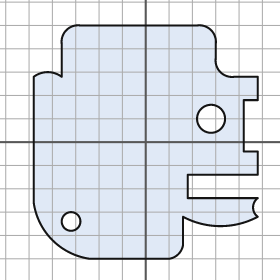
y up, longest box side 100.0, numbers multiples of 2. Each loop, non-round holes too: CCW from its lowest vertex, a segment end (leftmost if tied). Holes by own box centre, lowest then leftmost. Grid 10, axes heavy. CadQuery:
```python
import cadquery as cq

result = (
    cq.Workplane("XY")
    .moveTo(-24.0, -50.0)
    .lineTo(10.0, -50.0)
    .threePointArc((14.0, -48.0), (16.0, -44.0))
    .lineTo(16.0, -32.0)
    .threePointArc((32.0, -36.0), (48.0, -32.0))
    .threePointArc((46.0, -28.0), (48.0, -24.0))
    .lineTo(18.0, -24.0)
    .lineTo(18.0, -14.0)
    .lineTo(48.0, -14.0)
    .lineTo(48.0, -4.0)
    .lineTo(42.0, -4.0)
    .lineTo(42.0, 18.0)
    .lineTo(48.0, 18.0)
    .lineTo(48.0, 28.0)
    .lineTo(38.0, 28.0)
    .threePointArc((32.0, 30.0), (30.0, 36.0))
    .lineTo(30.0, 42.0)
    .threePointArc((28.0, 48.0), (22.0, 50.0))
    .lineTo(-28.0, 50.0)
    .threePointArc((-34.0, 48.0), (-36.0, 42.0))
    .lineTo(-36.0, 28.0)
    .threePointArc((-42.0, 30.0), (-48.0, 28.0))
    .lineTo(-48.0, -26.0)
    .threePointArc((-40.0, -42.0), (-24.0, -50.0))
    .close()
    .moveTo(-32.0, -34.0)
    .circle(4.0)
    .moveTo(28.0, 10.0)
    .circle(6.0)
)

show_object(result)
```